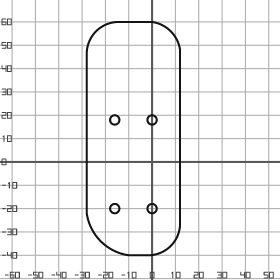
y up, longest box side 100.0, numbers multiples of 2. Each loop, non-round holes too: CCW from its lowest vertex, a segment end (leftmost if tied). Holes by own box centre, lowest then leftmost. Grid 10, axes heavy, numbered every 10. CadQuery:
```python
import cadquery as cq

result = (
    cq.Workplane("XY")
    .moveTo(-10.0, -40.0)
    .lineTo(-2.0, -40.0)
    .threePointArc((8.0, -36.0), (12.0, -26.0))
    .lineTo(12.0, 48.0)
    .threePointArc((8.0, 56.0), (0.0, 60.0))
    .lineTo(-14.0, 60.0)
    .threePointArc((-24.0, 56.0), (-28.0, 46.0))
    .lineTo(-28.0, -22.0)
    .threePointArc((-22.0, -34.0), (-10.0, -40.0))
    .close()
    .moveTo(-16.0, -20.0)
    .circle(2.0)
    .moveTo(0.0, -20.0)
    .circle(2.0)
    .moveTo(-16.0, 18.0)
    .circle(2.0)
    .moveTo(0.0, 18.0)
    .circle(2.0)
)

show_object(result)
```